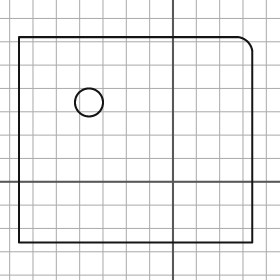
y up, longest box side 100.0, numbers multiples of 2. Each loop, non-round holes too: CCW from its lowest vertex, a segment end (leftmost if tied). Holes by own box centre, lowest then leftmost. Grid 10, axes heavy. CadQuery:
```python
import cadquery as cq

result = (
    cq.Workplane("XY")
    .moveTo(-66.0, -26.0)
    .lineTo(34.0, -26.0)
    .lineTo(34.0, 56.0)
    .threePointArc((32.0, 60.0), (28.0, 62.0))
    .lineTo(-66.0, 62.0)
    .close()
    .moveTo(-36.0, 34.0)
    .circle(6.0)
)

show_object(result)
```